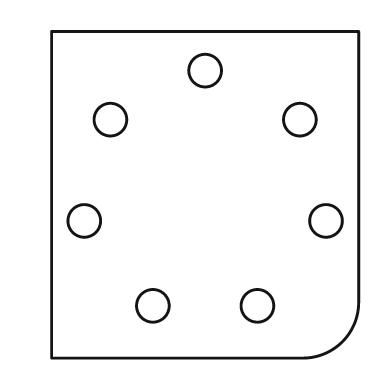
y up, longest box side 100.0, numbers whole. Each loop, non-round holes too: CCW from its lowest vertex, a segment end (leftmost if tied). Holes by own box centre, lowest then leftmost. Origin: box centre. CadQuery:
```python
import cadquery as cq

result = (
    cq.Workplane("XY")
    .moveTo(-47.0, -50.0)
    .lineTo(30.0, -50.0)
    .threePointArc((42.0, -45.0), (47.0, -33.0))
    .lineTo(47.0, 50.0)
    .lineTo(-47.0, 50.0)
    .close()
    .moveTo(-16.0, -34.0)
    .circle(5.0)
    .moveTo(16.0, -34.0)
    .circle(5.0)
    .moveTo(-37.0, -8.0)
    .circle(5.0)
    .moveTo(37.0, -8.0)
    .circle(5.0)
    .moveTo(-29.0, 23.0)
    .circle(5.0)
    .moveTo(29.0, 23.0)
    .circle(5.0)
    .moveTo(0.0, 38.0)
    .circle(5.0)
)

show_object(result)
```